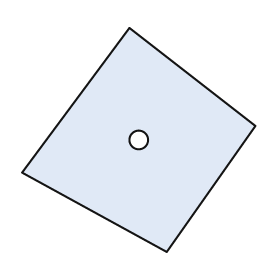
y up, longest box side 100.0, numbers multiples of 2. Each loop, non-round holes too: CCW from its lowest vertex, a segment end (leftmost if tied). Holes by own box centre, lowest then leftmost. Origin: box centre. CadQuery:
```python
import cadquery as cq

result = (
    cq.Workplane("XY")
    .moveTo(12.0, -48.0)
    .lineTo(50.0, 6.0)
    .lineTo(-4.0, 48.0)
    .lineTo(-50.0, -14.0)
    .close()
    .moveTo(0.0, 0.0)
    .circle(4.0)
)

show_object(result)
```